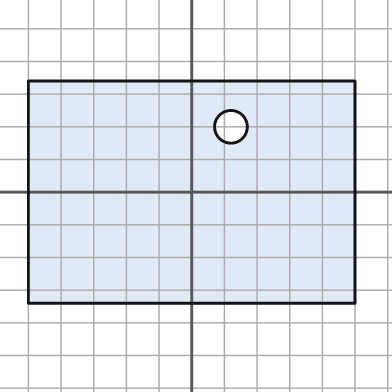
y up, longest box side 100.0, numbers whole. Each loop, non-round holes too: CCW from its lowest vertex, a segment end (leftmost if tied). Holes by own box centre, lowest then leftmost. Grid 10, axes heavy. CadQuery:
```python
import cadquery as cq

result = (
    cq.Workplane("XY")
    .moveTo(-50.0, -34.0)
    .lineTo(50.0, -34.0)
    .lineTo(50.0, 34.0)
    .lineTo(-50.0, 34.0)
    .close()
    .moveTo(12.0, 20.0)
    .circle(5.0)
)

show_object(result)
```